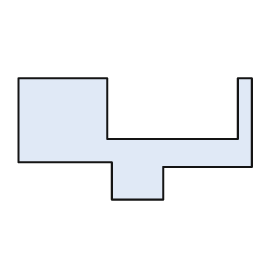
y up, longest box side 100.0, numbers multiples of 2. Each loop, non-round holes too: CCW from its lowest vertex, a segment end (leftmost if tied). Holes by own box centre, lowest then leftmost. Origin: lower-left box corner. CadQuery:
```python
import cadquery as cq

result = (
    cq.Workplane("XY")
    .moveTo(40.0, 0.0)
    .lineTo(62.0, 0.0)
    .lineTo(62.0, 14.0)
    .lineTo(100.0, 14.0)
    .lineTo(100.0, 52.0)
    .lineTo(94.0, 52.0)
    .lineTo(94.0, 26.0)
    .lineTo(38.0, 26.0)
    .lineTo(38.0, 52.0)
    .lineTo(0.0, 52.0)
    .lineTo(0.0, 16.0)
    .lineTo(40.0, 16.0)
    .close()
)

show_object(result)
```